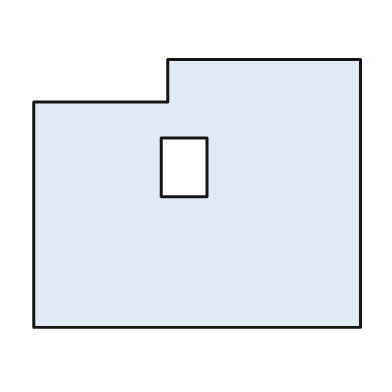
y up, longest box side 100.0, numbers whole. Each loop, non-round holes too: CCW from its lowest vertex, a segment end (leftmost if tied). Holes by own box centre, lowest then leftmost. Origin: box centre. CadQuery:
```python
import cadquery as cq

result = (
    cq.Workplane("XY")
    .moveTo(-50.0, -41.0)
    .lineTo(50.0, -41.0)
    .lineTo(50.0, 41.0)
    .lineTo(-9.0, 41.0)
    .lineTo(-9.0, 28.0)
    .lineTo(-50.0, 28.0)
    .close()
    .moveTo(-11.0, -1.0)
    .lineTo(3.0, -1.0)
    .lineTo(3.0, 17.0)
    .lineTo(-11.0, 17.0)
    .close()
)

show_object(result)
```